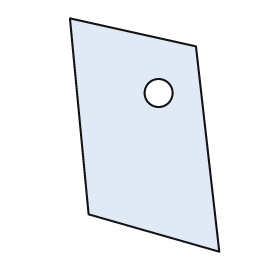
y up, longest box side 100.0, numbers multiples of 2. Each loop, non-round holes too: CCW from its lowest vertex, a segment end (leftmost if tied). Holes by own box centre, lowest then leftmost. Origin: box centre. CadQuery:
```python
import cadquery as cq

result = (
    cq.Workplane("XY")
    .moveTo(32.0, -50.0)
    .lineTo(22.0, 38.0)
    .lineTo(-32.0, 50.0)
    .lineTo(-24.0, -34.0)
    .close()
    .moveTo(6.0, 18.0)
    .circle(6.0)
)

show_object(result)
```